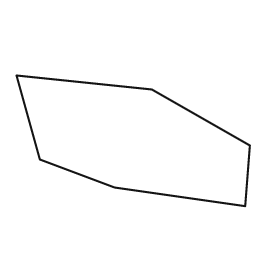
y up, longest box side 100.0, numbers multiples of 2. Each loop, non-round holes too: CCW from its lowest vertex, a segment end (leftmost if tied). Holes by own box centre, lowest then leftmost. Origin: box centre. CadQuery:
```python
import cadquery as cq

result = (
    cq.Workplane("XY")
    .moveTo(48.0, -28.0)
    .lineTo(50.0, -2.0)
    .lineTo(8.0, 22.0)
    .lineTo(-50.0, 28.0)
    .lineTo(-40.0, -8.0)
    .lineTo(-8.0, -20.0)
    .close()
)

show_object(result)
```